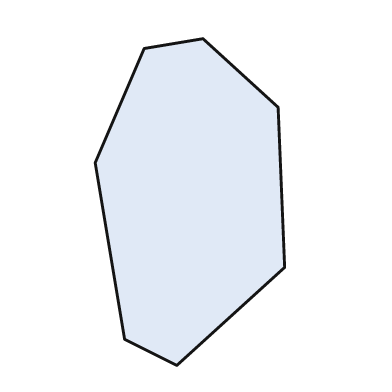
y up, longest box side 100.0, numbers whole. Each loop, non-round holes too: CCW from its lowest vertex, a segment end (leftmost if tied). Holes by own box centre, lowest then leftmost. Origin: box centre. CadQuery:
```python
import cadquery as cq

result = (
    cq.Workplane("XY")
    .moveTo(-4.0, -50.0)
    .lineTo(29.0, -20.0)
    .lineTo(27.0, 29.0)
    .lineTo(4.0, 50.0)
    .lineTo(-14.0, 47.0)
    .lineTo(-29.0, 12.0)
    .lineTo(-20.0, -42.0)
    .close()
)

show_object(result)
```